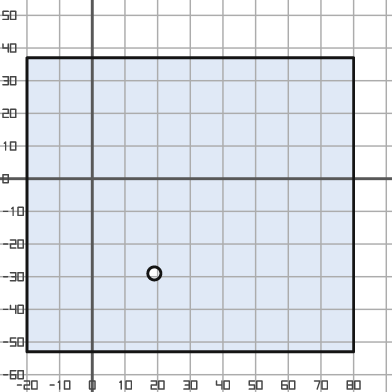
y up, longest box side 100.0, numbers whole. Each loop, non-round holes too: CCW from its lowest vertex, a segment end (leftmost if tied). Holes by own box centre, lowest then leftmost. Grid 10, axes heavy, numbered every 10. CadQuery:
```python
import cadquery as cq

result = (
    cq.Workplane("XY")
    .moveTo(-20.0, -53.0)
    .lineTo(80.0, -53.0)
    .lineTo(80.0, 37.0)
    .lineTo(-20.0, 37.0)
    .close()
    .moveTo(19.0, -29.0)
    .circle(2.0)
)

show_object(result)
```